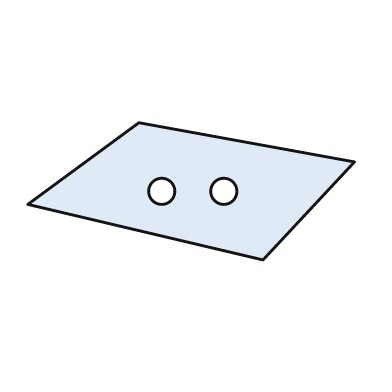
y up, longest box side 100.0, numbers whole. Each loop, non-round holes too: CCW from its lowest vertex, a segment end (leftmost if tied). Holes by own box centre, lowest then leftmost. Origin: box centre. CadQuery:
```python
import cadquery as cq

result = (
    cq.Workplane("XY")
    .moveTo(22.0, -21.0)
    .lineTo(50.0, 9.0)
    .lineTo(-16.0, 21.0)
    .lineTo(-50.0, -4.0)
    .close()
    .moveTo(-9.0, 0.0)
    .circle(4.0)
    .moveTo(10.0, 0.0)
    .circle(4.0)
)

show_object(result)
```